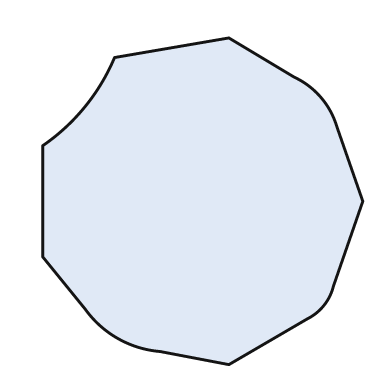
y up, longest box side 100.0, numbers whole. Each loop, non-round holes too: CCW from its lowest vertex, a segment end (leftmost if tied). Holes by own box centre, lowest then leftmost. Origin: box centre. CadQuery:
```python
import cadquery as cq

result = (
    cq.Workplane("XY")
    .moveTo(8.0, -50.0)
    .lineTo(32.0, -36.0)
    .threePointArc((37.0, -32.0), (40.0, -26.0))
    .lineTo(49.0, 0.0)
    .lineTo(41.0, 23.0)
    .threePointArc((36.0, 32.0), (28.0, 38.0))
    .lineTo(8.0, 50.0)
    .lineTo(-27.0, 44.0)
    .threePointArc((-36.0, 29.0), (-49.0, 17.0))
    .lineTo(-49.0, -17.0)
    .lineTo(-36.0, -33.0)
    .threePointArc((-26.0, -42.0), (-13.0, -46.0))
    .close()
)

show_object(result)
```